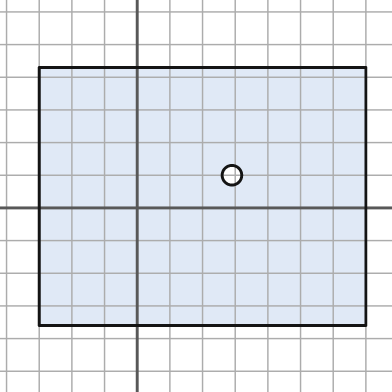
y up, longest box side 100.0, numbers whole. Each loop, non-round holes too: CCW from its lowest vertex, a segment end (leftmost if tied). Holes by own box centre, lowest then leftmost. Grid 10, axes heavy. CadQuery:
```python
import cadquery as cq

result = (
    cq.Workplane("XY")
    .moveTo(-30.0, -36.0)
    .lineTo(70.0, -36.0)
    .lineTo(70.0, 43.0)
    .lineTo(-30.0, 43.0)
    .close()
    .moveTo(29.0, 10.0)
    .circle(3.0)
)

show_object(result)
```